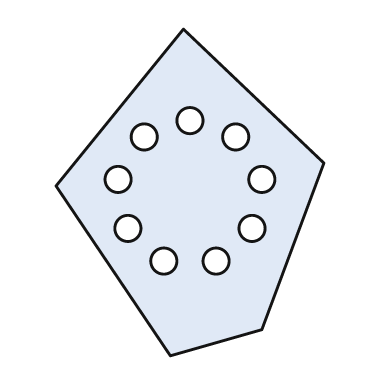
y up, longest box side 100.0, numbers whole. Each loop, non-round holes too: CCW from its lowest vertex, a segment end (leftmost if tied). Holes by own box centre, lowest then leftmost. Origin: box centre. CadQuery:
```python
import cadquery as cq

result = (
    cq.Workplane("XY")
    .moveTo(-6.0, -50.0)
    .lineTo(22.0, -42.0)
    .lineTo(41.0, 9.0)
    .lineTo(-2.0, 50.0)
    .lineTo(-41.0, 2.0)
    .close()
    .moveTo(-8.0, -21.0)
    .circle(4.0)
    .moveTo(8.0, -21.0)
    .circle(4.0)
    .moveTo(-19.0, -11.0)
    .circle(4.0)
    .moveTo(19.0, -11.0)
    .circle(4.0)
    .moveTo(-22.0, 4.0)
    .circle(4.0)
    .moveTo(22.0, 4.0)
    .circle(4.0)
    .moveTo(-14.0, 17.0)
    .circle(4.0)
    .moveTo(14.0, 17.0)
    .circle(4.0)
    .moveTo(0.0, 22.0)
    .circle(4.0)
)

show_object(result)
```